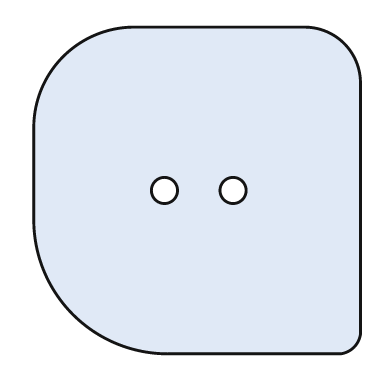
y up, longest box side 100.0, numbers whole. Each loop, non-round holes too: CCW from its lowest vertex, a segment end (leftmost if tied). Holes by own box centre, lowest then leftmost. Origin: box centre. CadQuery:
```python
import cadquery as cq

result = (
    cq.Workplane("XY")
    .moveTo(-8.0, -50.0)
    .lineTo(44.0, -50.0)
    .threePointArc((48.0, -48.0), (50.0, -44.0))
    .lineTo(50.0, 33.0)
    .threePointArc((45.0, 45.0), (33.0, 50.0))
    .lineTo(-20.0, 50.0)
    .threePointArc((-41.0, 41.0), (-50.0, 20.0))
    .lineTo(-50.0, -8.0)
    .threePointArc((-38.0, -38.0), (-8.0, -50.0))
    .close()
    .moveTo(-10.0, 0.0)
    .circle(4.0)
    .moveTo(11.0, 0.0)
    .circle(4.0)
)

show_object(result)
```